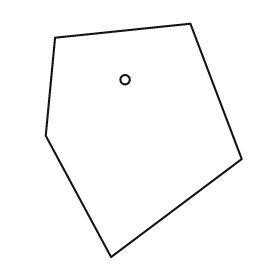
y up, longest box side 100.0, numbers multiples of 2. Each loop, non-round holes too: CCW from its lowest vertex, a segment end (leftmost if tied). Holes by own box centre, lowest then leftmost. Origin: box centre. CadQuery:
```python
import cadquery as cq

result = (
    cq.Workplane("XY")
    .moveTo(-14.0, -50.0)
    .lineTo(42.0, -8.0)
    .lineTo(20.0, 50.0)
    .lineTo(-38.0, 44.0)
    .lineTo(-42.0, 2.0)
    .close()
    .moveTo(-8.0, 26.0)
    .circle(2.0)
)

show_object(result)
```